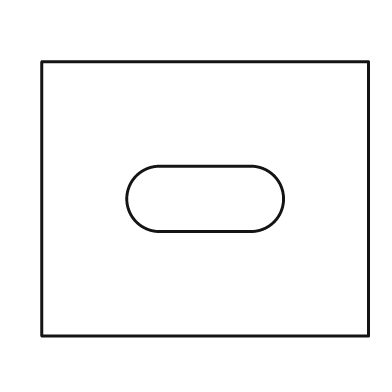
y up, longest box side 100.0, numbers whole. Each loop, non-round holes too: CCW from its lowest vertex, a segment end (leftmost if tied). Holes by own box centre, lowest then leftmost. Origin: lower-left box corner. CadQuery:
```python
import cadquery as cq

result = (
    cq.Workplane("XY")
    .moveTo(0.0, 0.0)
    .lineTo(100.0, 0.0)
    .lineTo(100.0, 84.0)
    .lineTo(0.0, 84.0)
    .close()
    .moveTo(36.0, 32.0)
    .lineTo(64.0, 32.0)
    .threePointArc((74.0, 42.0), (64.0, 52.0))
    .lineTo(36.0, 52.0)
    .threePointArc((26.0, 42.0), (36.0, 32.0))
    .close()
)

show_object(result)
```